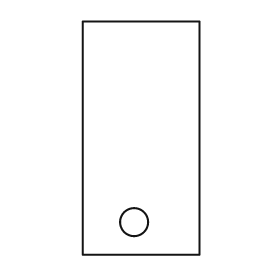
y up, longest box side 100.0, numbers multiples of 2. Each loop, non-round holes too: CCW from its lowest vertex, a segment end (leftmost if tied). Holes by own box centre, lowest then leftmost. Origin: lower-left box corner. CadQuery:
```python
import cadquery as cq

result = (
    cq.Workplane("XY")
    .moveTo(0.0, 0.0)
    .lineTo(50.0, 0.0)
    .lineTo(50.0, 100.0)
    .lineTo(0.0, 100.0)
    .close()
    .moveTo(22.0, 14.0)
    .circle(6.0)
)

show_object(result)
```